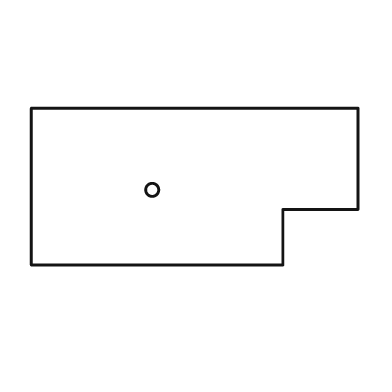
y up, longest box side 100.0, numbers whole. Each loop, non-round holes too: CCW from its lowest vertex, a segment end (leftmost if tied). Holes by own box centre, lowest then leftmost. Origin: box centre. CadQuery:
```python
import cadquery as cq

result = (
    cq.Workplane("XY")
    .moveTo(-50.0, -24.0)
    .lineTo(27.0, -24.0)
    .lineTo(27.0, -7.0)
    .lineTo(50.0, -7.0)
    .lineTo(50.0, 24.0)
    .lineTo(-50.0, 24.0)
    .close()
    .moveTo(-13.0, -1.0)
    .circle(2.0)
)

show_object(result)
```